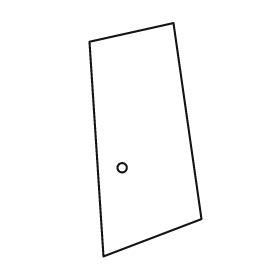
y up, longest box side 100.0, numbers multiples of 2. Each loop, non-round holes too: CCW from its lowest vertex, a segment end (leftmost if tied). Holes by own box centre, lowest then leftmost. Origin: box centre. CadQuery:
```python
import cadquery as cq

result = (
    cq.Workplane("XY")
    .moveTo(-18.0, -50.0)
    .lineTo(24.0, -34.0)
    .lineTo(12.0, 50.0)
    .lineTo(-24.0, 42.0)
    .close()
    .moveTo(-10.0, -12.0)
    .circle(2.0)
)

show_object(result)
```